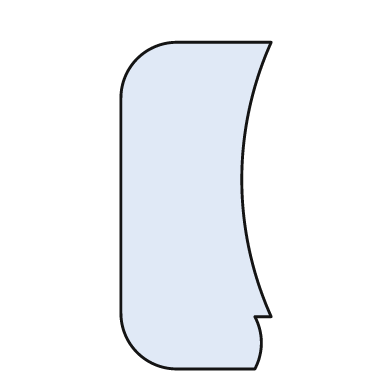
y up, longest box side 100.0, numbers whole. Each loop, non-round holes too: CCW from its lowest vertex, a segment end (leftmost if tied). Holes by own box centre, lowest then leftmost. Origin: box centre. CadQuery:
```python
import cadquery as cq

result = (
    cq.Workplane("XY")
    .moveTo(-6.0, -50.0)
    .lineTo(18.0, -50.0)
    .threePointArc((20.0, -42.0), (18.0, -34.0))
    .lineTo(23.0, -34.0)
    .threePointArc((14.0, 8.0), (23.0, 50.0))
    .lineTo(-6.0, 50.0)
    .threePointArc((-18.0, 45.0), (-23.0, 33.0))
    .lineTo(-23.0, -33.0)
    .threePointArc((-18.0, -45.0), (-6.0, -50.0))
    .close()
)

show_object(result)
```